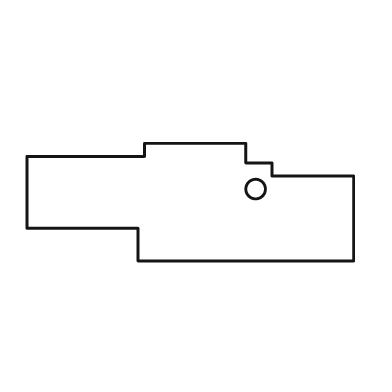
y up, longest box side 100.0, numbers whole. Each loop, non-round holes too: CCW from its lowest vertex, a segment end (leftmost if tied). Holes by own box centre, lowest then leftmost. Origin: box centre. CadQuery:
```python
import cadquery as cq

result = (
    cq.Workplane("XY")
    .moveTo(-16.0, -18.0)
    .lineTo(50.0, -18.0)
    .lineTo(50.0, 8.0)
    .lineTo(25.0, 8.0)
    .lineTo(25.0, 12.0)
    .lineTo(17.0, 12.0)
    .lineTo(17.0, 18.0)
    .lineTo(-14.0, 18.0)
    .lineTo(-14.0, 14.0)
    .lineTo(-50.0, 14.0)
    .lineTo(-50.0, -8.0)
    .lineTo(-16.0, -8.0)
    .close()
    .moveTo(20.0, 4.0)
    .circle(3.0)
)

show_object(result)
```